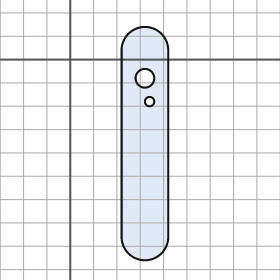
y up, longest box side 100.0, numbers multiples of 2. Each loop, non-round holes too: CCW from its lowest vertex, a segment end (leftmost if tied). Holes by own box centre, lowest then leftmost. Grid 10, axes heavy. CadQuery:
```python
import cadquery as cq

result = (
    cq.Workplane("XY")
    .moveTo(22.0, -76.0)
    .threePointArc((32.0, -86.0), (42.0, -76.0))
    .lineTo(42.0, 4.0)
    .threePointArc((32.0, 14.0), (22.0, 4.0))
    .close()
    .moveTo(34.0, -18.0)
    .circle(2.0)
    .moveTo(32.0, -8.0)
    .circle(4.0)
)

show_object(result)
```